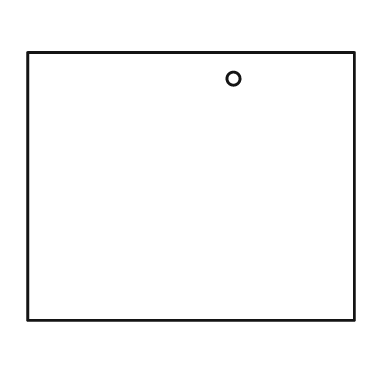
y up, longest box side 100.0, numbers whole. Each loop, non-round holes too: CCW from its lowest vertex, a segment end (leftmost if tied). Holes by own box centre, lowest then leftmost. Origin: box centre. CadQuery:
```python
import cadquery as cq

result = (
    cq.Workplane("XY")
    .moveTo(-50.0, -41.0)
    .lineTo(50.0, -41.0)
    .lineTo(50.0, 41.0)
    .lineTo(-50.0, 41.0)
    .close()
    .moveTo(13.0, 33.0)
    .circle(2.0)
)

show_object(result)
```